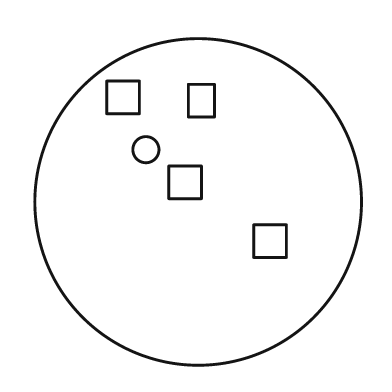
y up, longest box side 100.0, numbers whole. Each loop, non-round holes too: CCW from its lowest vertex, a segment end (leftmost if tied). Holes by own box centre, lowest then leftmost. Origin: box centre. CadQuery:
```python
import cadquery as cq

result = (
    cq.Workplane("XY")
    .moveTo(0.0, 0.0)
    .circle(50.0)
    .moveTo(17.0, -17.0)
    .lineTo(27.0, -17.0)
    .lineTo(27.0, -7.0)
    .lineTo(17.0, -7.0)
    .close()
    .moveTo(-9.0, 1.0)
    .lineTo(1.0, 1.0)
    .lineTo(1.0, 11.0)
    .lineTo(-9.0, 11.0)
    .close()
    .moveTo(-16.0, 16.0)
    .circle(4.0)
    .moveTo(-3.0, 26.0)
    .lineTo(5.0, 26.0)
    .lineTo(5.0, 36.0)
    .lineTo(-3.0, 36.0)
    .close()
    .moveTo(-28.0, 27.0)
    .lineTo(-18.0, 27.0)
    .lineTo(-18.0, 37.0)
    .lineTo(-28.0, 37.0)
    .close()
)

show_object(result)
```